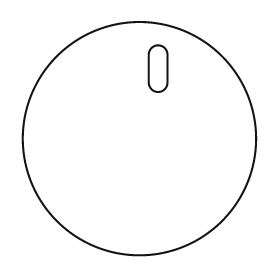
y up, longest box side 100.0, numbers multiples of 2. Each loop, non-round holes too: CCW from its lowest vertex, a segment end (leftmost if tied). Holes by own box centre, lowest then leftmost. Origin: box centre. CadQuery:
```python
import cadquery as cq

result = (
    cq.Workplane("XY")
    .moveTo(0.0, 0.0)
    .circle(50.0)
    .moveTo(4.0, 24.0)
    .threePointArc((8.0, 20.0), (12.0, 24.0))
    .lineTo(12.0, 36.0)
    .threePointArc((8.0, 40.0), (4.0, 36.0))
    .close()
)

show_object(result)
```